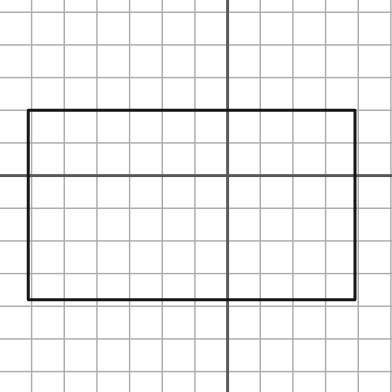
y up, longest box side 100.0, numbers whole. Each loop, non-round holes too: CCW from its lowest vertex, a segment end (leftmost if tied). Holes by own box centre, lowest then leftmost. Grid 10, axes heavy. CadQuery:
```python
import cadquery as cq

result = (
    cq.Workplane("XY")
    .moveTo(-61.0, -38.0)
    .lineTo(39.0, -38.0)
    .lineTo(39.0, 20.0)
    .lineTo(-61.0, 20.0)
    .close()
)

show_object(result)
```